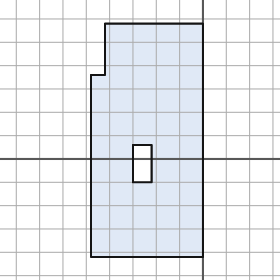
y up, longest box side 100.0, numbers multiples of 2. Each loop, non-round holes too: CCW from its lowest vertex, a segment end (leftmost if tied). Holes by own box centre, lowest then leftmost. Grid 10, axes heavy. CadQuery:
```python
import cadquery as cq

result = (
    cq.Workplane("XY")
    .moveTo(-48.0, -42.0)
    .lineTo(0.0, -42.0)
    .lineTo(0.0, 58.0)
    .lineTo(-42.0, 58.0)
    .lineTo(-42.0, 36.0)
    .lineTo(-48.0, 36.0)
    .close()
    .moveTo(-30.0, -10.0)
    .lineTo(-22.0, -10.0)
    .lineTo(-22.0, 6.0)
    .lineTo(-30.0, 6.0)
    .close()
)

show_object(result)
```